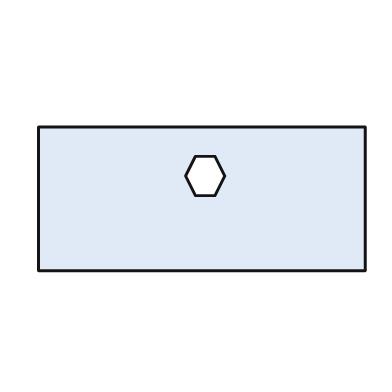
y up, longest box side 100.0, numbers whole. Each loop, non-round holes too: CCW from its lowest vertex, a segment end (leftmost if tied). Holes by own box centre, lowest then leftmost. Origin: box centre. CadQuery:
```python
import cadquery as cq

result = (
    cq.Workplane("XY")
    .moveTo(-50.0, -22.0)
    .lineTo(50.0, -22.0)
    .lineTo(50.0, 22.0)
    .lineTo(-50.0, 22.0)
    .close()
    .moveTo(-2.0, 1.0)
    .lineTo(4.0, 1.0)
    .lineTo(7.0, 7.0)
    .lineTo(4.0, 13.0)
    .lineTo(-2.0, 13.0)
    .lineTo(-5.0, 7.0)
    .close()
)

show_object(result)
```